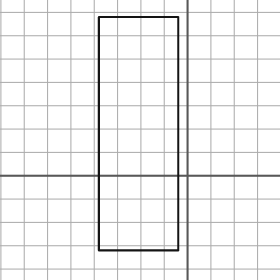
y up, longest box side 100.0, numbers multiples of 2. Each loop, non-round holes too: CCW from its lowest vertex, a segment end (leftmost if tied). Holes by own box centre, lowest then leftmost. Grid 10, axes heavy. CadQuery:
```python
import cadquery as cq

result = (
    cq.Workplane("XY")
    .moveTo(-38.0, -32.0)
    .lineTo(-4.0, -32.0)
    .lineTo(-4.0, 68.0)
    .lineTo(-38.0, 68.0)
    .close()
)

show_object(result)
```